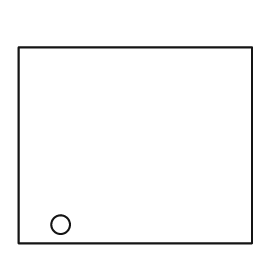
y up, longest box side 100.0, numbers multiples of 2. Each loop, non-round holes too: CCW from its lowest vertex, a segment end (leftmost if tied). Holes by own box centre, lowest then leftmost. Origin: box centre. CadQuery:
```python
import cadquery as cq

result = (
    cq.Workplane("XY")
    .moveTo(-50.0, -42.0)
    .lineTo(50.0, -42.0)
    .lineTo(50.0, 42.0)
    .lineTo(-50.0, 42.0)
    .close()
    .moveTo(-32.0, -34.0)
    .circle(4.0)
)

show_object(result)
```